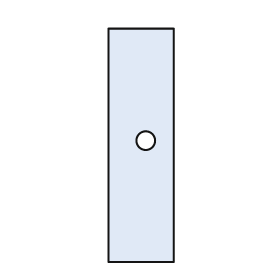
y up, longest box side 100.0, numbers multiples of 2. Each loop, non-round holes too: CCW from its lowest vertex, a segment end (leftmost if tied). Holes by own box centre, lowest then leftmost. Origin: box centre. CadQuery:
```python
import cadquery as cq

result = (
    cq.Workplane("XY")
    .moveTo(-14.0, -50.0)
    .lineTo(14.0, -50.0)
    .lineTo(14.0, 50.0)
    .lineTo(-14.0, 50.0)
    .close()
    .moveTo(2.0, 2.0)
    .circle(4.0)
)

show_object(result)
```